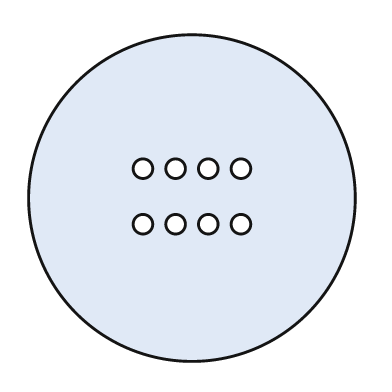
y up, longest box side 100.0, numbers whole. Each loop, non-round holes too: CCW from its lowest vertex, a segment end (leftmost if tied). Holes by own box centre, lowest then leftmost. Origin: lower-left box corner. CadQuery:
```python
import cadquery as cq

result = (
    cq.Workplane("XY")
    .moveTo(50.0, 50.0)
    .circle(50.0)
    .moveTo(35.0, 42.0)
    .circle(3.0)
    .moveTo(45.0, 42.0)
    .circle(3.0)
    .moveTo(55.0, 42.0)
    .circle(3.0)
    .moveTo(65.0, 42.0)
    .circle(3.0)
    .moveTo(35.0, 59.0)
    .circle(3.0)
    .moveTo(45.0, 59.0)
    .circle(3.0)
    .moveTo(55.0, 59.0)
    .circle(3.0)
    .moveTo(65.0, 59.0)
    .circle(3.0)
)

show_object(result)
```